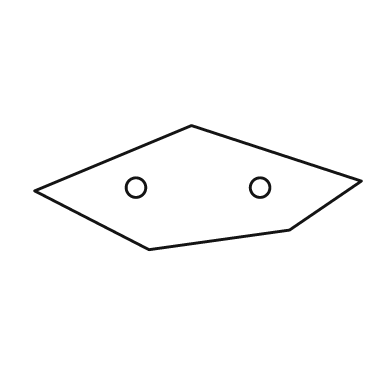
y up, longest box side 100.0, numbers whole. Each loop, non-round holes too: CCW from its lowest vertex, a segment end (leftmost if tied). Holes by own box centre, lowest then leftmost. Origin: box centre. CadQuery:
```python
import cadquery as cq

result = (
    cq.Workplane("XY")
    .moveTo(-15.0, -19.0)
    .lineTo(28.0, -13.0)
    .lineTo(50.0, 2.0)
    .lineTo(-2.0, 19.0)
    .lineTo(-50.0, -1.0)
    .close()
    .moveTo(-19.0, 0.0)
    .circle(3.0)
    .moveTo(19.0, 0.0)
    .circle(3.0)
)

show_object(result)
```